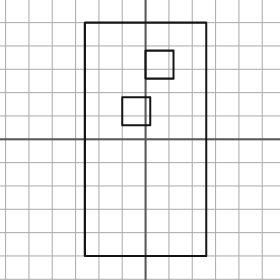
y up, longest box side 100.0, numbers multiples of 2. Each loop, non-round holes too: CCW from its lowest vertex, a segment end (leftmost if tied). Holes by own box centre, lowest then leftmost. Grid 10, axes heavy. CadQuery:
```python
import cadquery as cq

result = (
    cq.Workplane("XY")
    .moveTo(-26.0, -50.0)
    .lineTo(26.0, -50.0)
    .lineTo(26.0, 50.0)
    .lineTo(-26.0, 50.0)
    .close()
    .moveTo(-10.0, 6.0)
    .lineTo(2.0, 6.0)
    .lineTo(2.0, 18.0)
    .lineTo(-10.0, 18.0)
    .close()
    .moveTo(0.0, 26.0)
    .lineTo(12.0, 26.0)
    .lineTo(12.0, 38.0)
    .lineTo(0.0, 38.0)
    .close()
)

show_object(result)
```